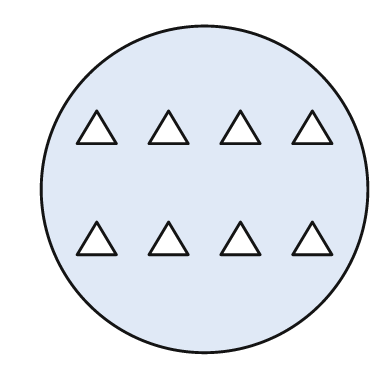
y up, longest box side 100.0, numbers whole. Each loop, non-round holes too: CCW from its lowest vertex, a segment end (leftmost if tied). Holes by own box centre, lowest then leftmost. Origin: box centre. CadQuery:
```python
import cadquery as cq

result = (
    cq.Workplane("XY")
    .moveTo(0.0, 0.0)
    .circle(50.0)
    .moveTo(-39.0, -20.0)
    .lineTo(-27.0, -20.0)
    .lineTo(-33.0, -10.0)
    .close()
    .moveTo(-17.0, -20.0)
    .lineTo(-5.0, -20.0)
    .lineTo(-11.0, -10.0)
    .close()
    .moveTo(5.0, -20.0)
    .lineTo(17.0, -20.0)
    .lineTo(11.0, -10.0)
    .close()
    .moveTo(27.0, -20.0)
    .lineTo(39.0, -20.0)
    .lineTo(33.0, -10.0)
    .close()
    .moveTo(-39.0, 14.0)
    .lineTo(-27.0, 14.0)
    .lineTo(-33.0, 24.0)
    .close()
    .moveTo(-17.0, 14.0)
    .lineTo(-5.0, 14.0)
    .lineTo(-11.0, 24.0)
    .close()
    .moveTo(5.0, 14.0)
    .lineTo(17.0, 14.0)
    .lineTo(11.0, 24.0)
    .close()
    .moveTo(27.0, 14.0)
    .lineTo(39.0, 14.0)
    .lineTo(33.0, 24.0)
    .close()
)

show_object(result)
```